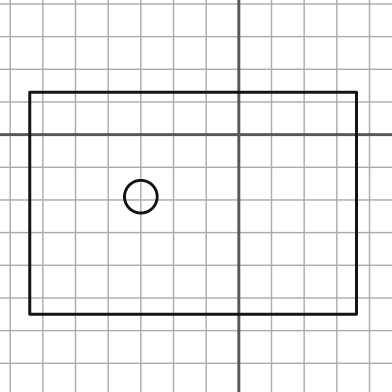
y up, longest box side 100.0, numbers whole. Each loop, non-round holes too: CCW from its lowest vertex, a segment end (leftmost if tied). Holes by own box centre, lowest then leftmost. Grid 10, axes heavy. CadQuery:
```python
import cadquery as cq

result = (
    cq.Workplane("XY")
    .moveTo(-64.0, -55.0)
    .lineTo(36.0, -55.0)
    .lineTo(36.0, 13.0)
    .lineTo(-64.0, 13.0)
    .close()
    .moveTo(-30.0, -19.0)
    .circle(5.0)
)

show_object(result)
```